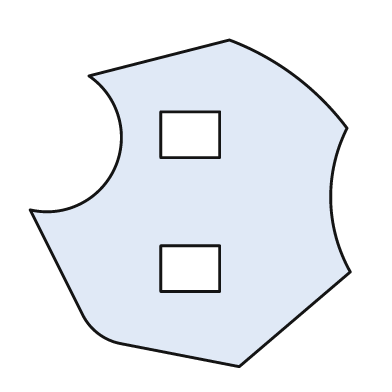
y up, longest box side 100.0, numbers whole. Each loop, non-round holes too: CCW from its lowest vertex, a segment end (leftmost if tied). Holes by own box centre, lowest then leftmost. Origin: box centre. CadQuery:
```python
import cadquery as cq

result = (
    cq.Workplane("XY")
    .moveTo(15.0, -50.0)
    .lineTo(49.0, -21.0)
    .threePointArc((43.0, 1.0), (48.0, 23.0))
    .threePointArc((32.0, 39.0), (12.0, 50.0))
    .lineTo(-31.0, 39.0)
    .threePointArc((-23.0, 11.0), (-49.0, -2.0))
    .lineTo(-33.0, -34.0)
    .threePointArc((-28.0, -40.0), (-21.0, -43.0))
    .close()
    .moveTo(-9.0, -27.0)
    .lineTo(9.0, -27.0)
    .lineTo(9.0, -13.0)
    .lineTo(-9.0, -13.0)
    .close()
    .moveTo(-9.0, 14.0)
    .lineTo(9.0, 14.0)
    .lineTo(9.0, 28.0)
    .lineTo(-9.0, 28.0)
    .close()
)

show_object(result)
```